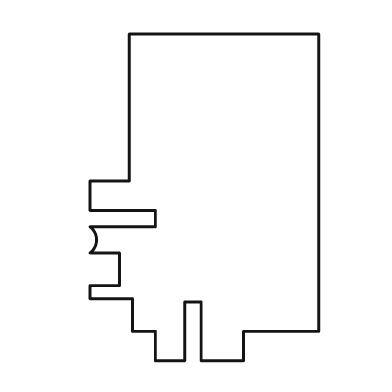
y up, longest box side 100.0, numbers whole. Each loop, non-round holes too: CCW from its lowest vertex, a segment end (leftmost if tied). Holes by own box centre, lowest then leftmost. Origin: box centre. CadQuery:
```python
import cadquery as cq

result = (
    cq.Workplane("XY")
    .moveTo(-15.0, -50.0)
    .lineTo(-6.0, -50.0)
    .lineTo(-6.0, -32.0)
    .lineTo(-1.0, -32.0)
    .lineTo(-1.0, -50.0)
    .lineTo(12.0, -50.0)
    .lineTo(12.0, -41.0)
    .lineTo(35.0, -41.0)
    .lineTo(35.0, 50.0)
    .lineTo(-23.0, 50.0)
    .lineTo(-23.0, 5.0)
    .lineTo(-35.0, 5.0)
    .lineTo(-35.0, -4.0)
    .lineTo(-15.0, -4.0)
    .lineTo(-15.0, -9.0)
    .lineTo(-35.0, -9.0)
    .threePointArc((-33.0, -13.0), (-35.0, -17.0))
    .lineTo(-26.0, -17.0)
    .lineTo(-26.0, -27.0)
    .lineTo(-35.0, -27.0)
    .lineTo(-35.0, -31.0)
    .lineTo(-22.0, -31.0)
    .lineTo(-22.0, -41.0)
    .lineTo(-15.0, -41.0)
    .close()
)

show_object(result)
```